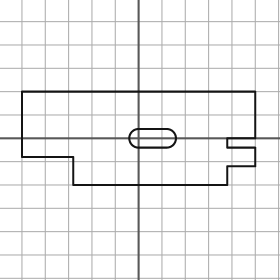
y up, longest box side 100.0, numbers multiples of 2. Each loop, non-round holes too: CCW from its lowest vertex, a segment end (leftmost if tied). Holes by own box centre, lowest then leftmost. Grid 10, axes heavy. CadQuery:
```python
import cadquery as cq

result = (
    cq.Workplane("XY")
    .moveTo(-28.0, -20.0)
    .lineTo(38.0, -20.0)
    .lineTo(38.0, -12.0)
    .lineTo(50.0, -12.0)
    .lineTo(50.0, -4.0)
    .lineTo(38.0, -4.0)
    .lineTo(38.0, 0.0)
    .lineTo(50.0, 0.0)
    .lineTo(50.0, 20.0)
    .lineTo(-50.0, 20.0)
    .lineTo(-50.0, -8.0)
    .lineTo(-28.0, -8.0)
    .close()
    .moveTo(0.0, -4.0)
    .lineTo(12.0, -4.0)
    .threePointArc((16.0, 0.0), (12.0, 4.0))
    .lineTo(0.0, 4.0)
    .threePointArc((-4.0, 0.0), (0.0, -4.0))
    .close()
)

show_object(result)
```